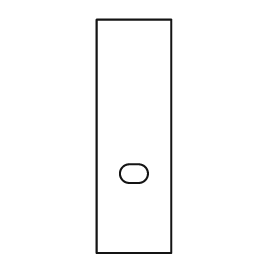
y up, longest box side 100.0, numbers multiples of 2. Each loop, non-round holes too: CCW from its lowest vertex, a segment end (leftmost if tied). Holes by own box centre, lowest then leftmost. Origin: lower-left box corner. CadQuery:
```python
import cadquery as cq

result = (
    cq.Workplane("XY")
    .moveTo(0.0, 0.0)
    .lineTo(32.0, 0.0)
    .lineTo(32.0, 100.0)
    .lineTo(0.0, 100.0)
    .close()
    .moveTo(14.0, 30.0)
    .lineTo(18.0, 30.0)
    .threePointArc((22.0, 34.0), (18.0, 38.0))
    .lineTo(14.0, 38.0)
    .threePointArc((10.0, 34.0), (14.0, 30.0))
    .close()
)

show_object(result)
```